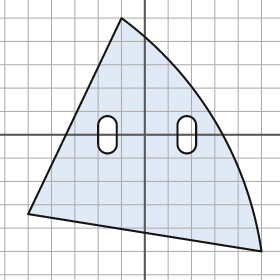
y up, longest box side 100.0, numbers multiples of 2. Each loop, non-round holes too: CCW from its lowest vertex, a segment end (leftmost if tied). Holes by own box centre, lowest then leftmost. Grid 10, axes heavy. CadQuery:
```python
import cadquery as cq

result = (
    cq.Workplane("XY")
    .moveTo(50.0, -50.0)
    .threePointArc((30.0, 6.0), (-10.0, 50.0))
    .lineTo(-50.0, -34.0)
    .close()
    .moveTo(-20.0, -4.0)
    .threePointArc((-16.0, -8.0), (-12.0, -4.0))
    .lineTo(-12.0, 4.0)
    .threePointArc((-16.0, 8.0), (-20.0, 4.0))
    .close()
    .moveTo(14.0, -4.0)
    .threePointArc((18.0, -8.0), (22.0, -4.0))
    .lineTo(22.0, 4.0)
    .threePointArc((18.0, 8.0), (14.0, 4.0))
    .close()
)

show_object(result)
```